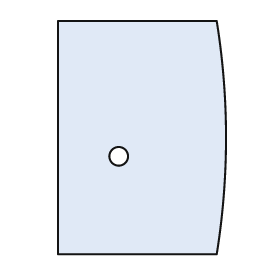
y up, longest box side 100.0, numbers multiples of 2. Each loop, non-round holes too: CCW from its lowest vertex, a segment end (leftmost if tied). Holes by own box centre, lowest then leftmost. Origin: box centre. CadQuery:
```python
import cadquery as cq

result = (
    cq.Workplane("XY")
    .moveTo(-36.0, -50.0)
    .lineTo(32.0, -50.0)
    .threePointArc((36.0, 0.0), (32.0, 50.0))
    .lineTo(-36.0, 50.0)
    .close()
    .moveTo(-10.0, -8.0)
    .circle(4.0)
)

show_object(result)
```